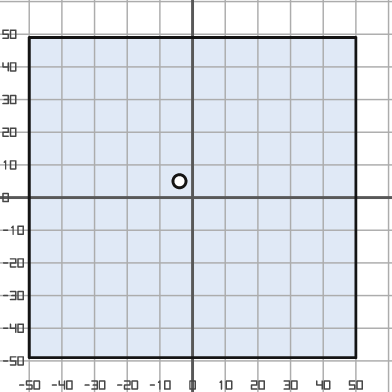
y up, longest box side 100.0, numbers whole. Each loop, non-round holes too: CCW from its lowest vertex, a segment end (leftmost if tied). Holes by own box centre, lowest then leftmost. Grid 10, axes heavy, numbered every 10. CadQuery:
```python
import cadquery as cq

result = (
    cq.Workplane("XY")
    .moveTo(-50.0, -49.0)
    .lineTo(50.0, -49.0)
    .lineTo(50.0, 49.0)
    .lineTo(-50.0, 49.0)
    .close()
    .moveTo(-4.0, 5.0)
    .circle(2.0)
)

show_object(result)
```